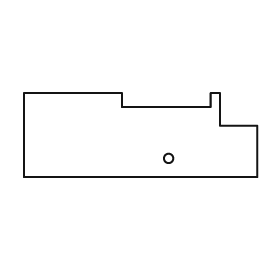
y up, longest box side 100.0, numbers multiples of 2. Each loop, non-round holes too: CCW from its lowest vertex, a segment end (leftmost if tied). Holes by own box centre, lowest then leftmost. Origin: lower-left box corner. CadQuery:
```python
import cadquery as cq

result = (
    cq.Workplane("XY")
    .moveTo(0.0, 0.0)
    .lineTo(100.0, 0.0)
    .lineTo(100.0, 22.0)
    .lineTo(84.0, 22.0)
    .lineTo(84.0, 36.0)
    .lineTo(80.0, 36.0)
    .lineTo(80.0, 30.0)
    .lineTo(42.0, 30.0)
    .lineTo(42.0, 36.0)
    .lineTo(0.0, 36.0)
    .close()
    .moveTo(62.0, 8.0)
    .circle(2.0)
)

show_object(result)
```